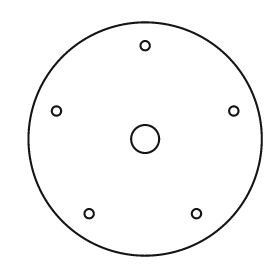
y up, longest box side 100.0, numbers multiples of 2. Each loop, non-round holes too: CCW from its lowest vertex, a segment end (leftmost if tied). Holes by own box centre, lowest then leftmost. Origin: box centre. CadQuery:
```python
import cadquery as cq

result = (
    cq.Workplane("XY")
    .moveTo(0.0, 0.0)
    .circle(50.0)
    .moveTo(-24.0, -32.0)
    .circle(2.0)
    .moveTo(22.0, -32.0)
    .circle(2.0)
    .moveTo(0.0, 0.0)
    .circle(6.0)
    .moveTo(-38.0, 12.0)
    .circle(2.0)
    .moveTo(38.0, 12.0)
    .circle(2.0)
    .moveTo(0.0, 40.0)
    .circle(2.0)
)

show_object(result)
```